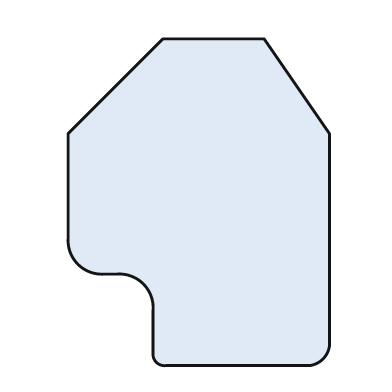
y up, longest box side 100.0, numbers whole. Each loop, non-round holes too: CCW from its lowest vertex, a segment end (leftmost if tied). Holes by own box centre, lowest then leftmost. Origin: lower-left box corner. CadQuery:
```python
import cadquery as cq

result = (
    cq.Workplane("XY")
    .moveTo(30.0, 0.0)
    .lineTo(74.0, 0.0)
    .threePointArc((78.0, 2.0), (80.0, 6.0))
    .lineTo(80.0, 71.0)
    .lineTo(60.0, 100.0)
    .lineTo(29.0, 100.0)
    .lineTo(0.0, 71.0)
    .lineTo(0.0, 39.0)
    .threePointArc((3.0, 31.0), (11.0, 28.0))
    .lineTo(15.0, 28.0)
    .threePointArc((23.0, 25.0), (26.0, 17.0))
    .lineTo(26.0, 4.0)
    .threePointArc((27.0, 1.0), (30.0, 0.0))
    .close()
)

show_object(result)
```